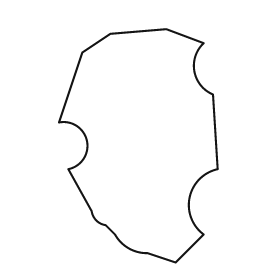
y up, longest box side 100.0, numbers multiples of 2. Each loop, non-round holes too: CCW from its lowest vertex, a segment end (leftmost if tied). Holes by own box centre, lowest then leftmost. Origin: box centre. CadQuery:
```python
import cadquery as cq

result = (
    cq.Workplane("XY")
    .moveTo(16.0, -50.0)
    .lineTo(28.0, -38.0)
    .threePointArc((22.0, -22.0), (34.0, -10.0))
    .lineTo(32.0, 22.0)
    .threePointArc((24.0, 32.0), (28.0, 44.0))
    .lineTo(12.0, 50.0)
    .lineTo(-12.0, 48.0)
    .lineTo(-24.0, 40.0)
    .lineTo(-34.0, 10.0)
    .threePointArc((-22.0, 2.0), (-30.0, -10.0))
    .lineTo(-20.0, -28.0)
    .threePointArc((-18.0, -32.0), (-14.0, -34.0))
    .lineTo(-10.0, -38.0)
    .threePointArc((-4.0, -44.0), (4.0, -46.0))
    .close()
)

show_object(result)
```